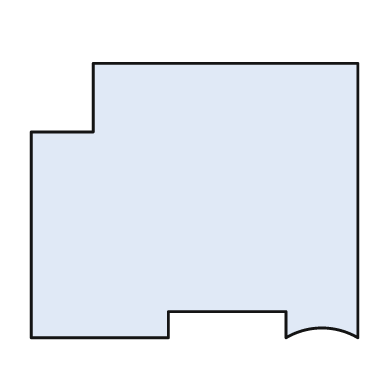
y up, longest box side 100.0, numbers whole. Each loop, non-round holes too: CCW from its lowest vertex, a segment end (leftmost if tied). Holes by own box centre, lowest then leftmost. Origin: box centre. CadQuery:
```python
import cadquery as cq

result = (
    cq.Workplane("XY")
    .moveTo(-50.0, -42.0)
    .lineTo(-8.0, -42.0)
    .lineTo(-8.0, -34.0)
    .lineTo(28.0, -34.0)
    .lineTo(28.0, -42.0)
    .threePointArc((39.0, -39.0), (50.0, -42.0))
    .lineTo(50.0, 42.0)
    .lineTo(-31.0, 42.0)
    .lineTo(-31.0, 21.0)
    .lineTo(-50.0, 21.0)
    .close()
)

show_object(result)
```